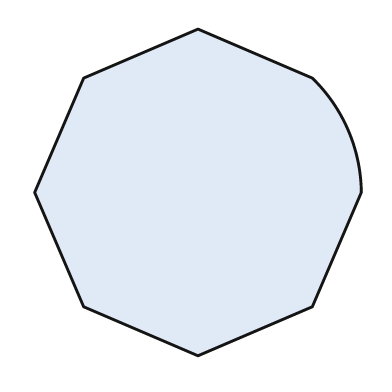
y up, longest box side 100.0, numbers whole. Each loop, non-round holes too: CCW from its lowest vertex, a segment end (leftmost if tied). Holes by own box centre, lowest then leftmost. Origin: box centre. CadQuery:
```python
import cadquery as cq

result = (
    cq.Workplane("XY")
    .moveTo(0.0, -50.0)
    .lineTo(35.0, -35.0)
    .lineTo(50.0, 0.0)
    .threePointArc((46.0, 19.0), (35.0, 35.0))
    .lineTo(0.0, 50.0)
    .lineTo(-35.0, 35.0)
    .lineTo(-50.0, 0.0)
    .lineTo(-35.0, -35.0)
    .close()
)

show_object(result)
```